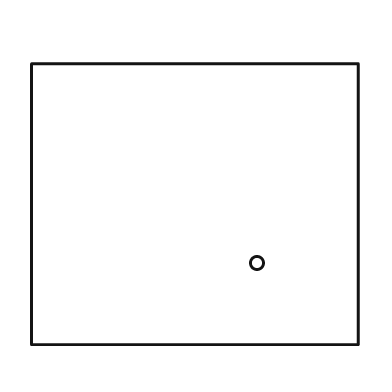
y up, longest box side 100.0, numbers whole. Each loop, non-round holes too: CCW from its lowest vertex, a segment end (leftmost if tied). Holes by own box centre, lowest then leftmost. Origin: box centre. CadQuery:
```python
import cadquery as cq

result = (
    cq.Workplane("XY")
    .moveTo(-50.0, -43.0)
    .lineTo(50.0, -43.0)
    .lineTo(50.0, 43.0)
    .lineTo(-50.0, 43.0)
    .close()
    .moveTo(19.0, -18.0)
    .circle(2.0)
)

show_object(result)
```